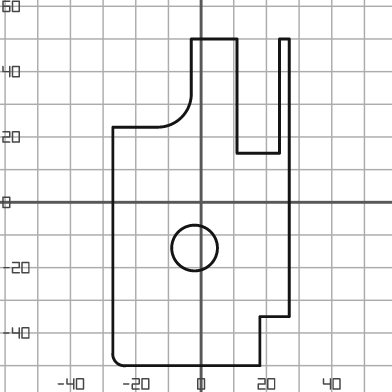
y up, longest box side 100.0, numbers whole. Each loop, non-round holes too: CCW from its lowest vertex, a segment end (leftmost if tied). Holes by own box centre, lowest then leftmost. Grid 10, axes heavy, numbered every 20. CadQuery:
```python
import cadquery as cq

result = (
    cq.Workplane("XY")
    .moveTo(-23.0, -50.0)
    .lineTo(18.0, -50.0)
    .lineTo(18.0, -35.0)
    .lineTo(27.0, -35.0)
    .lineTo(27.0, 50.0)
    .lineTo(24.0, 50.0)
    .lineTo(24.0, 15.0)
    .lineTo(11.0, 15.0)
    .lineTo(11.0, 50.0)
    .lineTo(-3.0, 50.0)
    .lineTo(-3.0, 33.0)
    .threePointArc((-6.0, 26.0), (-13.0, 23.0))
    .lineTo(-27.0, 23.0)
    .lineTo(-27.0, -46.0)
    .threePointArc((-26.0, -49.0), (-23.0, -50.0))
    .close()
    .moveTo(-2.0, -14.0)
    .circle(7.0)
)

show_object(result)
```